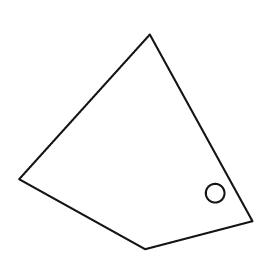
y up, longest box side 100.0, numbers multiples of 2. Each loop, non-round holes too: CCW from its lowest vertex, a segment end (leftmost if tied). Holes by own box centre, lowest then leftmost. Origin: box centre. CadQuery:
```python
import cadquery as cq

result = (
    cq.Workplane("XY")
    .moveTo(4.0, -46.0)
    .lineTo(50.0, -34.0)
    .lineTo(6.0, 46.0)
    .lineTo(-50.0, -16.0)
    .close()
    .moveTo(34.0, -22.0)
    .circle(4.0)
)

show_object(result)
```